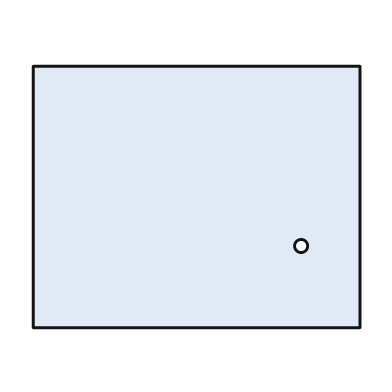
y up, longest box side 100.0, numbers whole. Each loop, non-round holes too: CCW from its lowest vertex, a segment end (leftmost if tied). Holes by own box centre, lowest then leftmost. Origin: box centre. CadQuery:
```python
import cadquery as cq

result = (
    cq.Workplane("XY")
    .moveTo(-50.0, -40.0)
    .lineTo(50.0, -40.0)
    .lineTo(50.0, 40.0)
    .lineTo(-50.0, 40.0)
    .close()
    .moveTo(32.0, -15.0)
    .circle(2.0)
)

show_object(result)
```